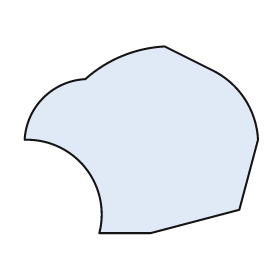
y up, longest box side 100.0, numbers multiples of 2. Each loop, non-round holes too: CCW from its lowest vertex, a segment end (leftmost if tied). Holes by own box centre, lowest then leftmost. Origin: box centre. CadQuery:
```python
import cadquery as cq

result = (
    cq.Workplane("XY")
    .moveTo(-18.0, -40.0)
    .lineTo(4.0, -40.0)
    .lineTo(42.0, -30.0)
    .lineTo(50.0, 0.0)
    .threePointArc((44.0, 18.0), (30.0, 30.0))
    .lineTo(10.0, 40.0)
    .threePointArc((-8.0, 36.0), (-24.0, 26.0))
    .threePointArc((-42.0, 18.0), (-50.0, 0.0))
    .threePointArc((-24.0, -12.0), (-18.0, -40.0))
    .close()
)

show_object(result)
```